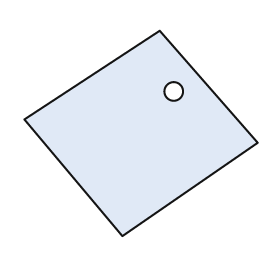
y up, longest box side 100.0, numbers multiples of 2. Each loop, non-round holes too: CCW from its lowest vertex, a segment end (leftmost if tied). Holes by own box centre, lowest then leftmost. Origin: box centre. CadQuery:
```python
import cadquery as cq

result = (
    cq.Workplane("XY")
    .moveTo(-8.0, -44.0)
    .lineTo(50.0, -4.0)
    .lineTo(8.0, 44.0)
    .lineTo(-50.0, 6.0)
    .close()
    .moveTo(14.0, 18.0)
    .circle(4.0)
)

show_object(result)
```